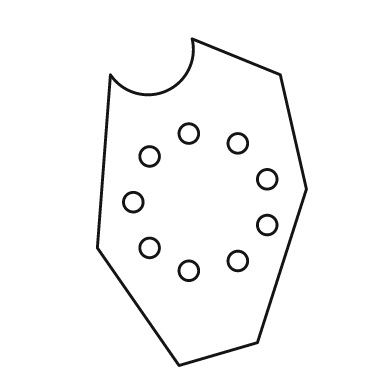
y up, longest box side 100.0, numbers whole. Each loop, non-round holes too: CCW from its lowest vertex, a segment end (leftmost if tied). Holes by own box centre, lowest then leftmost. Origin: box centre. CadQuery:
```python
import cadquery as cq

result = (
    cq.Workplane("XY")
    .moveTo(-7.0, -50.0)
    .lineTo(17.0, -43.0)
    .lineTo(32.0, 4.0)
    .lineTo(24.0, 39.0)
    .lineTo(-3.0, 50.0)
    .threePointArc((-11.0, 34.0), (-28.0, 39.0))
    .lineTo(-32.0, -14.0)
    .close()
    .moveTo(-4.0, -21.0)
    .circle(3.0)
    .moveTo(11.0, -18.0)
    .circle(3.0)
    .moveTo(-16.0, -14.0)
    .circle(3.0)
    .moveTo(20.0, -7.0)
    .circle(3.0)
    .moveTo(-21.0, 0.0)
    .circle(3.0)
    .moveTo(20.0, 7.0)
    .circle(3.0)
    .moveTo(-16.0, 14.0)
    .circle(3.0)
    .moveTo(11.0, 18.0)
    .circle(3.0)
    .moveTo(-4.0, 21.0)
    .circle(3.0)
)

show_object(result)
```